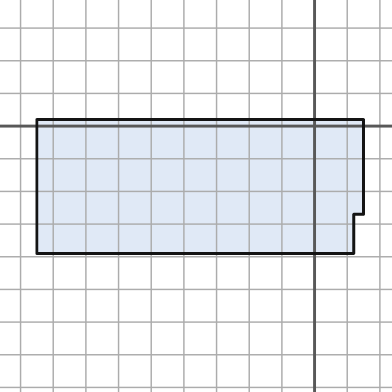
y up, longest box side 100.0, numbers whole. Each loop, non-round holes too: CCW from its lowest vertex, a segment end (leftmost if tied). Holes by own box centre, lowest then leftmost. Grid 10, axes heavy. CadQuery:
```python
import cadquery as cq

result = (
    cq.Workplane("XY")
    .moveTo(-85.0, -39.0)
    .lineTo(12.0, -39.0)
    .lineTo(12.0, -27.0)
    .lineTo(15.0, -27.0)
    .lineTo(15.0, 2.0)
    .lineTo(-85.0, 2.0)
    .close()
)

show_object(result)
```